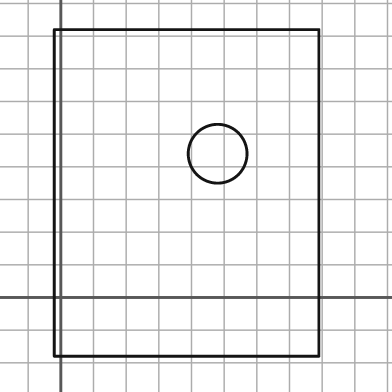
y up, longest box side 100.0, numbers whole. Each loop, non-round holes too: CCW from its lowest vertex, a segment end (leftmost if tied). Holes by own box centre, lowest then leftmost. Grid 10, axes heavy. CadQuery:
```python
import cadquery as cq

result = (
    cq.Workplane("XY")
    .moveTo(-2.0, -18.0)
    .lineTo(79.0, -18.0)
    .lineTo(79.0, 82.0)
    .lineTo(-2.0, 82.0)
    .close()
    .moveTo(48.0, 44.0)
    .circle(9.0)
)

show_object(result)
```